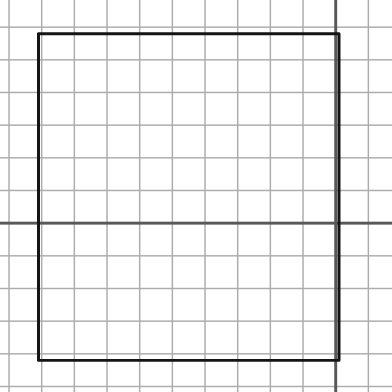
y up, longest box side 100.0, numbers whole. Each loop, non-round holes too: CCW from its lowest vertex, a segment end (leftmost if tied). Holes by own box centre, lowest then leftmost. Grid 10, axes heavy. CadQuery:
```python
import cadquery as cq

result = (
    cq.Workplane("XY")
    .moveTo(-91.0, -42.0)
    .lineTo(1.0, -42.0)
    .lineTo(1.0, 58.0)
    .lineTo(-91.0, 58.0)
    .close()
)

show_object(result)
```